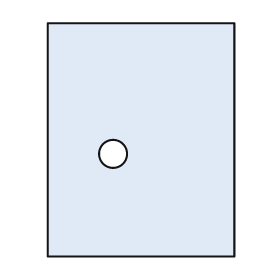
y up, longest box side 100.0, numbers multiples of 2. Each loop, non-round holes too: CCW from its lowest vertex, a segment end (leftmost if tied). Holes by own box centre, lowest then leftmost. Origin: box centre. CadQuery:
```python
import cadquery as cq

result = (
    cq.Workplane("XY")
    .moveTo(-40.0, -50.0)
    .lineTo(40.0, -50.0)
    .lineTo(40.0, 50.0)
    .lineTo(-40.0, 50.0)
    .close()
    .moveTo(-12.0, -6.0)
    .circle(6.0)
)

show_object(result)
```